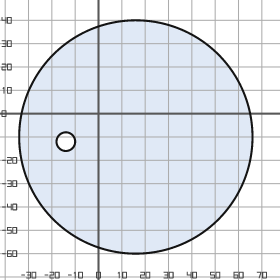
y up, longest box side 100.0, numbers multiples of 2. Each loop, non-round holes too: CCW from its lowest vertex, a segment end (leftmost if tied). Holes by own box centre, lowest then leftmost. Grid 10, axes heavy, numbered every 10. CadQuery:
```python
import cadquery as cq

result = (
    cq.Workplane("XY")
    .moveTo(16.0, -10.0)
    .circle(50.0)
    .moveTo(-14.0, -12.0)
    .circle(4.0)
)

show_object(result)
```